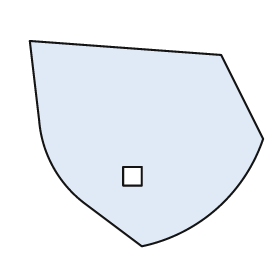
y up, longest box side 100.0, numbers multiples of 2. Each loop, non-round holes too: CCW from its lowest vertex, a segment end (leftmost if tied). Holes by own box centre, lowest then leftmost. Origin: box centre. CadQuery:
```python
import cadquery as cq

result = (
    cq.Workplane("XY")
    .moveTo(-2.0, -44.0)
    .threePointArc((30.0, -28.0), (50.0, 2.0))
    .lineTo(32.0, 38.0)
    .lineTo(-50.0, 44.0)
    .lineTo(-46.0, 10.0)
    .threePointArc((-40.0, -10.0), (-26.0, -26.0))
    .close()
    .moveTo(-10.0, -18.0)
    .lineTo(-2.0, -18.0)
    .lineTo(-2.0, -10.0)
    .lineTo(-10.0, -10.0)
    .close()
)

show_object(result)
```